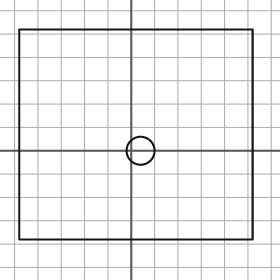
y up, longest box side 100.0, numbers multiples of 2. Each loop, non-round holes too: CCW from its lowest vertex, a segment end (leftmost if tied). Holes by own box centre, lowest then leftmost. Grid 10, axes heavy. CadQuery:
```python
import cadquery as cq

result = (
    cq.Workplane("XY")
    .moveTo(-48.0, -38.0)
    .lineTo(52.0, -38.0)
    .lineTo(52.0, 52.0)
    .lineTo(-48.0, 52.0)
    .close()
    .moveTo(4.0, 0.0)
    .circle(6.0)
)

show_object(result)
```